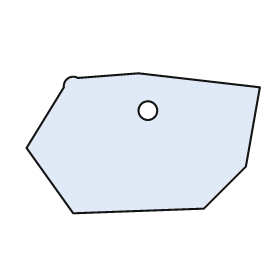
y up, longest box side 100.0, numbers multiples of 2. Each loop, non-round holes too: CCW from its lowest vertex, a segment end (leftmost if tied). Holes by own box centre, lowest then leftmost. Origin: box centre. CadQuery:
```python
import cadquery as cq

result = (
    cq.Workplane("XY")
    .moveTo(-30.0, -30.0)
    .lineTo(26.0, -28.0)
    .lineTo(44.0, -10.0)
    .lineTo(50.0, 24.0)
    .lineTo(-2.0, 30.0)
    .lineTo(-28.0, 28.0)
    .threePointArc((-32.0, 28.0), (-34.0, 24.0))
    .lineTo(-50.0, -2.0)
    .close()
    .moveTo(2.0, 14.0)
    .circle(4.0)
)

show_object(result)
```